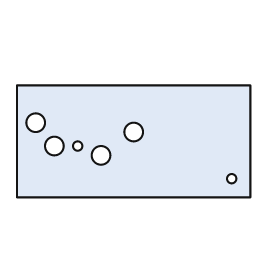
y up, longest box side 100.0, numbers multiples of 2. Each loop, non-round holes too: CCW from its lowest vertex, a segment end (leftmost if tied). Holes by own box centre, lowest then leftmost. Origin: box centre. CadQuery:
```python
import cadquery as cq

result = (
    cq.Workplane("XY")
    .moveTo(-50.0, -24.0)
    .lineTo(50.0, -24.0)
    .lineTo(50.0, 24.0)
    .lineTo(-50.0, 24.0)
    .close()
    .moveTo(42.0, -16.0)
    .circle(2.0)
    .moveTo(-14.0, -6.0)
    .circle(4.0)
    .moveTo(-34.0, -2.0)
    .circle(4.0)
    .moveTo(-24.0, -2.0)
    .circle(2.0)
    .moveTo(0.0, 4.0)
    .circle(4.0)
    .moveTo(-42.0, 8.0)
    .circle(4.0)
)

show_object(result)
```